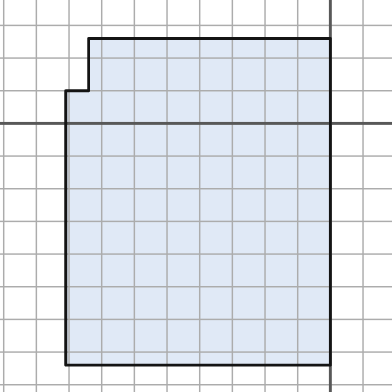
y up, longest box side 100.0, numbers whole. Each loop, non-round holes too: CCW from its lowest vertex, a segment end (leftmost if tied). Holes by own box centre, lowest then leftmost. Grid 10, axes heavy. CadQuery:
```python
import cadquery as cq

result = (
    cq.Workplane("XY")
    .moveTo(-81.0, -74.0)
    .lineTo(0.0, -74.0)
    .lineTo(0.0, 26.0)
    .lineTo(-74.0, 26.0)
    .lineTo(-74.0, 10.0)
    .lineTo(-81.0, 10.0)
    .close()
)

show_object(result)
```